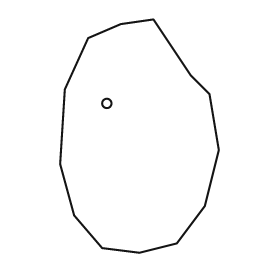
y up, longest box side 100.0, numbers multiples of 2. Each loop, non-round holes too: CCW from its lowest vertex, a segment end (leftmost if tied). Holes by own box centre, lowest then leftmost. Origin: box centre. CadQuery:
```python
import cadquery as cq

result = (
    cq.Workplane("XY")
    .moveTo(0.0, -50.0)
    .lineTo(16.0, -46.0)
    .lineTo(28.0, -30.0)
    .lineTo(34.0, -6.0)
    .lineTo(30.0, 18.0)
    .lineTo(22.0, 26.0)
    .lineTo(6.0, 50.0)
    .lineTo(-8.0, 48.0)
    .lineTo(-22.0, 42.0)
    .lineTo(-32.0, 20.0)
    .lineTo(-34.0, -12.0)
    .lineTo(-28.0, -34.0)
    .lineTo(-16.0, -48.0)
    .close()
    .moveTo(-14.0, 14.0)
    .circle(2.0)
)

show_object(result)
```